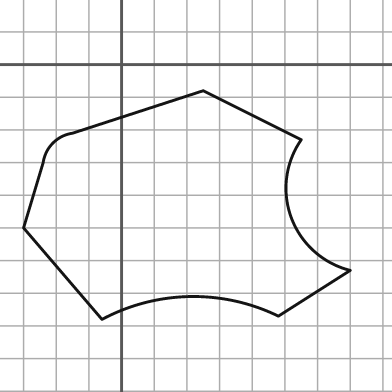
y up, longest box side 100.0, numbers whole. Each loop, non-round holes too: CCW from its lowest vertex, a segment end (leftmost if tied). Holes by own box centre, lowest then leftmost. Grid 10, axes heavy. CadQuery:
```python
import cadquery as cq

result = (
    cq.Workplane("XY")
    .moveTo(-6.0, -78.0)
    .threePointArc((21.0, -71.0), (48.0, -77.0))
    .lineTo(70.0, -63.0)
    .threePointArc((52.0, -47.0), (55.0, -23.0))
    .lineTo(25.0, -8.0)
    .lineTo(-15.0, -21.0)
    .threePointArc((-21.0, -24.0), (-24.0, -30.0))
    .lineTo(-30.0, -50.0)
    .close()
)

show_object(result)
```